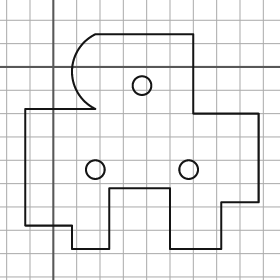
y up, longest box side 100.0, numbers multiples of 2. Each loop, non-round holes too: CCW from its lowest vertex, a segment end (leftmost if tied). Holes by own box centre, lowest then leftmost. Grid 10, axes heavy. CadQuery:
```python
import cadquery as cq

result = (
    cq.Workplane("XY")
    .moveTo(8.0, -78.0)
    .lineTo(24.0, -78.0)
    .lineTo(24.0, -52.0)
    .lineTo(50.0, -52.0)
    .lineTo(50.0, -78.0)
    .lineTo(72.0, -78.0)
    .lineTo(72.0, -58.0)
    .lineTo(88.0, -58.0)
    .lineTo(88.0, -20.0)
    .lineTo(60.0, -20.0)
    .lineTo(60.0, 14.0)
    .lineTo(18.0, 14.0)
    .threePointArc((8.0, -2.0), (18.0, -18.0))
    .lineTo(-12.0, -18.0)
    .lineTo(-12.0, -68.0)
    .lineTo(8.0, -68.0)
    .close()
    .moveTo(18.0, -44.0)
    .circle(4.0)
    .moveTo(58.0, -44.0)
    .circle(4.0)
    .moveTo(38.0, -8.0)
    .circle(4.0)
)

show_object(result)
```